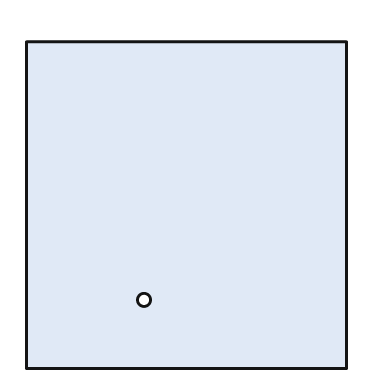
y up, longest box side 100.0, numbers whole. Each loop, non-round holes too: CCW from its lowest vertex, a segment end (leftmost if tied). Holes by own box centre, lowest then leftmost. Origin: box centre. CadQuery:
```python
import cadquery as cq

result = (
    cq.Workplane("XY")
    .moveTo(-49.0, -50.0)
    .lineTo(49.0, -50.0)
    .lineTo(49.0, 50.0)
    .lineTo(-49.0, 50.0)
    .close()
    .moveTo(-13.0, -29.0)
    .circle(2.0)
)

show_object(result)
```